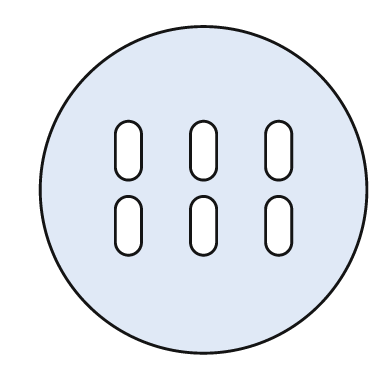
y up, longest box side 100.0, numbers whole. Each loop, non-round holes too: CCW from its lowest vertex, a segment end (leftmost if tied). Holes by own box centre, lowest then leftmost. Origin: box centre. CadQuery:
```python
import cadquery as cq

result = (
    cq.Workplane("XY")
    .moveTo(0.0, 0.0)
    .circle(50.0)
    .moveTo(-27.0, -16.0)
    .threePointArc((-23.0, -20.0), (-19.0, -16.0))
    .lineTo(-19.0, -6.0)
    .threePointArc((-23.0, -2.0), (-27.0, -6.0))
    .close()
    .moveTo(-4.0, -16.0)
    .threePointArc((0.0, -20.0), (4.0, -16.0))
    .lineTo(4.0, -6.0)
    .threePointArc((0.0, -2.0), (-4.0, -6.0))
    .close()
    .moveTo(19.0, -16.0)
    .threePointArc((23.0, -20.0), (27.0, -16.0))
    .lineTo(27.0, -6.0)
    .threePointArc((23.0, -2.0), (19.0, -6.0))
    .close()
    .moveTo(-27.0, 7.0)
    .threePointArc((-23.0, 3.0), (-19.0, 7.0))
    .lineTo(-19.0, 17.0)
    .threePointArc((-23.0, 21.0), (-27.0, 17.0))
    .close()
    .moveTo(-4.0, 7.0)
    .threePointArc((0.0, 3.0), (4.0, 7.0))
    .lineTo(4.0, 17.0)
    .threePointArc((0.0, 21.0), (-4.0, 17.0))
    .close()
    .moveTo(19.0, 7.0)
    .threePointArc((23.0, 3.0), (27.0, 7.0))
    .lineTo(27.0, 17.0)
    .threePointArc((23.0, 21.0), (19.0, 17.0))
    .close()
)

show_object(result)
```